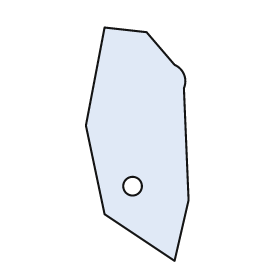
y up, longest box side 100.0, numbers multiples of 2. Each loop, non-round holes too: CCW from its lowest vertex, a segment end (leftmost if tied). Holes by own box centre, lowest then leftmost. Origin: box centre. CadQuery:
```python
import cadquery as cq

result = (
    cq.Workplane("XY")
    .moveTo(16.0, -50.0)
    .lineTo(22.0, -24.0)
    .lineTo(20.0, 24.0)
    .threePointArc((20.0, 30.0), (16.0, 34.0))
    .lineTo(4.0, 48.0)
    .lineTo(-14.0, 50.0)
    .lineTo(-22.0, 8.0)
    .lineTo(-14.0, -30.0)
    .close()
    .moveTo(-2.0, -18.0)
    .circle(4.0)
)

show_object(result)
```